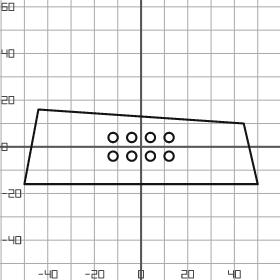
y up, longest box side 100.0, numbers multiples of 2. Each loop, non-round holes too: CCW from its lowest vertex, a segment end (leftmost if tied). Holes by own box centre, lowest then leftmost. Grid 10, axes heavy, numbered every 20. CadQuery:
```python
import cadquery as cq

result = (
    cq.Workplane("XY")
    .moveTo(-50.0, -16.0)
    .lineTo(50.0, -16.0)
    .lineTo(44.0, 10.0)
    .lineTo(-44.0, 16.0)
    .close()
    .moveTo(-12.0, -4.0)
    .circle(2.0)
    .moveTo(-4.0, -4.0)
    .circle(2.0)
    .moveTo(4.0, -4.0)
    .circle(2.0)
    .moveTo(12.0, -4.0)
    .circle(2.0)
    .moveTo(-12.0, 4.0)
    .circle(2.0)
    .moveTo(-4.0, 4.0)
    .circle(2.0)
    .moveTo(4.0, 4.0)
    .circle(2.0)
    .moveTo(12.0, 4.0)
    .circle(2.0)
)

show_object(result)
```